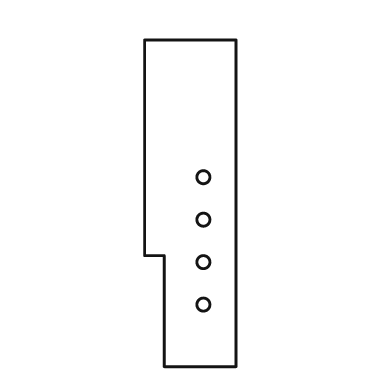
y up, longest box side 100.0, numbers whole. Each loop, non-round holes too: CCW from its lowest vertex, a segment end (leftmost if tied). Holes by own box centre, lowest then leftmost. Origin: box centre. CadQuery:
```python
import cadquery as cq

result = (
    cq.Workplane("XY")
    .moveTo(-8.0, -50.0)
    .lineTo(14.0, -50.0)
    .lineTo(14.0, 50.0)
    .lineTo(-14.0, 50.0)
    .lineTo(-14.0, -16.0)
    .lineTo(-8.0, -16.0)
    .close()
    .moveTo(4.0, -31.0)
    .circle(2.0)
    .moveTo(4.0, -18.0)
    .circle(2.0)
    .moveTo(4.0, -5.0)
    .circle(2.0)
    .moveTo(4.0, 8.0)
    .circle(2.0)
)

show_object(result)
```